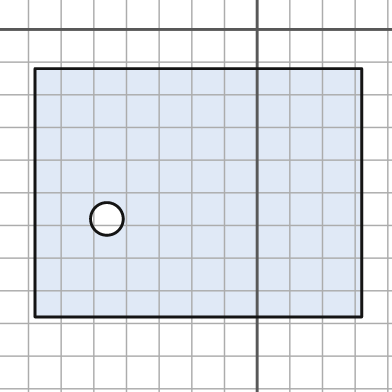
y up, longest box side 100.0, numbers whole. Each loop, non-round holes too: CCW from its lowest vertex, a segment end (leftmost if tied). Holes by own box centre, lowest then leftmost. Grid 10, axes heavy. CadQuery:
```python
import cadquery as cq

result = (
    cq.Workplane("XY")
    .moveTo(-68.0, -88.0)
    .lineTo(32.0, -88.0)
    .lineTo(32.0, -12.0)
    .lineTo(-68.0, -12.0)
    .close()
    .moveTo(-46.0, -58.0)
    .circle(5.0)
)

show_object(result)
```